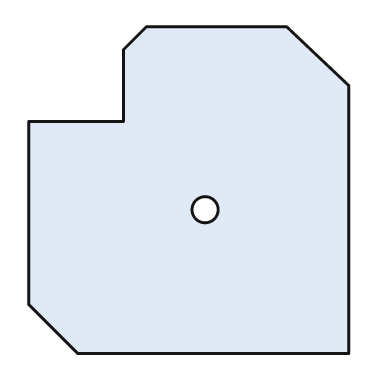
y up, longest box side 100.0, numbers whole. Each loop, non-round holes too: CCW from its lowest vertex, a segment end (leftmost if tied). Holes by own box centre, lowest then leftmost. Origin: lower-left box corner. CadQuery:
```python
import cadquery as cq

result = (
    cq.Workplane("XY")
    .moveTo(15.0, 0.0)
    .lineTo(98.0, 0.0)
    .lineTo(98.0, 82.0)
    .lineTo(79.0, 100.0)
    .lineTo(36.0, 100.0)
    .lineTo(29.0, 93.0)
    .lineTo(29.0, 71.0)
    .lineTo(0.0, 71.0)
    .lineTo(0.0, 15.0)
    .close()
    .moveTo(54.0, 44.0)
    .circle(4.0)
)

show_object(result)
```